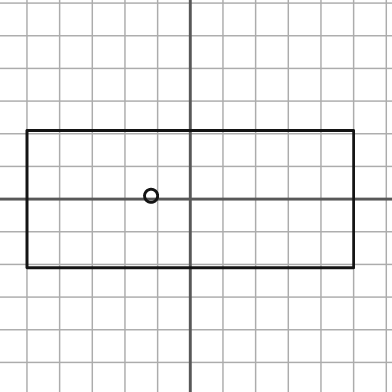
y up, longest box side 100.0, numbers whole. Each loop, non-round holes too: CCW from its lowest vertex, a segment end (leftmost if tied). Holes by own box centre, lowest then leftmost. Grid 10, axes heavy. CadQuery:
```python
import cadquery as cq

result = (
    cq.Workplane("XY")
    .moveTo(-50.0, -21.0)
    .lineTo(50.0, -21.0)
    .lineTo(50.0, 21.0)
    .lineTo(-50.0, 21.0)
    .close()
    .moveTo(-12.0, 1.0)
    .circle(2.0)
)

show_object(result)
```